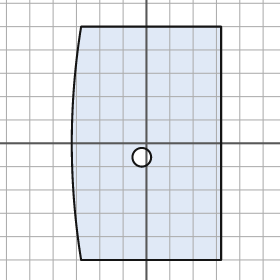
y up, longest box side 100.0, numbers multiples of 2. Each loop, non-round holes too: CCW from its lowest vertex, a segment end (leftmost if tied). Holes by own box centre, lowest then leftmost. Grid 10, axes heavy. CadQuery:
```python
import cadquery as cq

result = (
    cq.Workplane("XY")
    .moveTo(-28.0, -50.0)
    .lineTo(32.0, -50.0)
    .lineTo(32.0, 50.0)
    .lineTo(-28.0, 50.0)
    .threePointArc((-32.0, 0.0), (-28.0, -50.0))
    .close()
    .moveTo(-2.0, -6.0)
    .circle(4.0)
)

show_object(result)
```